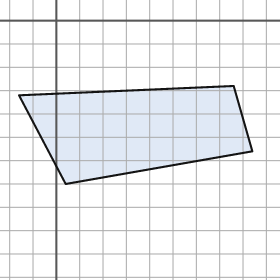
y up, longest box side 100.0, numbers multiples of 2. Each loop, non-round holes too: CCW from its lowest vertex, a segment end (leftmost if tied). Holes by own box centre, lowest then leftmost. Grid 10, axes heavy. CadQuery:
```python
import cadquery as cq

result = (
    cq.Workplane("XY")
    .moveTo(4.0, -70.0)
    .lineTo(84.0, -56.0)
    .lineTo(76.0, -28.0)
    .lineTo(-16.0, -32.0)
    .close()
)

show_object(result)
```